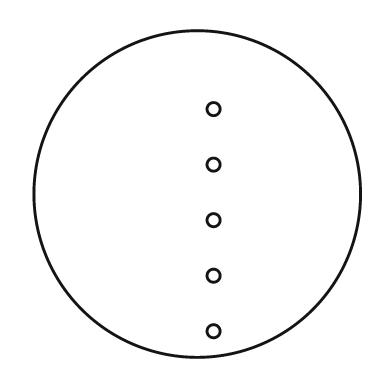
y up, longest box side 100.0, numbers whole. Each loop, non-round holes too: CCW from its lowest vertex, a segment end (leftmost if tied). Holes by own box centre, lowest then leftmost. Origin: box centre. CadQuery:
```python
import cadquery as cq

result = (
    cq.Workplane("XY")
    .moveTo(0.0, 0.0)
    .circle(50.0)
    .moveTo(5.0, -42.0)
    .circle(2.0)
    .moveTo(5.0, -25.0)
    .circle(2.0)
    .moveTo(5.0, -8.0)
    .circle(2.0)
    .moveTo(5.0, 9.0)
    .circle(2.0)
    .moveTo(5.0, 26.0)
    .circle(2.0)
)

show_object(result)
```